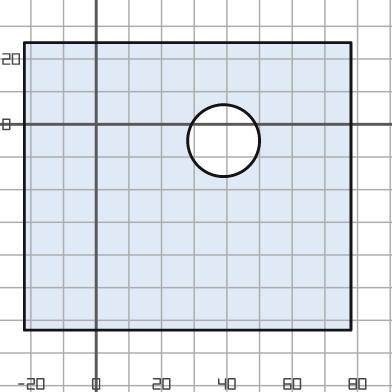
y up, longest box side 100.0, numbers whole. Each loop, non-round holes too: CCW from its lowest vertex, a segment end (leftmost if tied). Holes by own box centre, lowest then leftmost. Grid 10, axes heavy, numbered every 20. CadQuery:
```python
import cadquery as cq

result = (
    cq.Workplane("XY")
    .moveTo(-22.0, -63.0)
    .lineTo(78.0, -63.0)
    .lineTo(78.0, 25.0)
    .lineTo(-22.0, 25.0)
    .close()
    .moveTo(39.0, -5.0)
    .circle(11.0)
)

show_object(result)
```